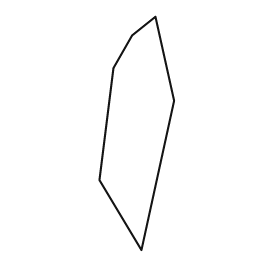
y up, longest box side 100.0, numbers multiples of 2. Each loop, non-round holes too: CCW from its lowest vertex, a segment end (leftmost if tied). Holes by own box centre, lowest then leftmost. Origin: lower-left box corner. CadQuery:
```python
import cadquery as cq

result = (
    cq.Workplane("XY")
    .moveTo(18.0, 0.0)
    .lineTo(32.0, 64.0)
    .lineTo(24.0, 100.0)
    .lineTo(14.0, 92.0)
    .lineTo(6.0, 78.0)
    .lineTo(0.0, 30.0)
    .close()
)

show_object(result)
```